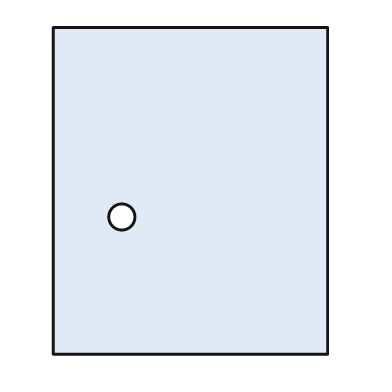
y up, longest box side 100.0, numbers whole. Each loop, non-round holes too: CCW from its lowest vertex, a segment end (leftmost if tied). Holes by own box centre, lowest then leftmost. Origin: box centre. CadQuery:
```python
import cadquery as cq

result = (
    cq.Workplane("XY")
    .moveTo(-42.0, -50.0)
    .lineTo(42.0, -50.0)
    .lineTo(42.0, 50.0)
    .lineTo(-42.0, 50.0)
    .close()
    .moveTo(-21.0, -8.0)
    .circle(4.0)
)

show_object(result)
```